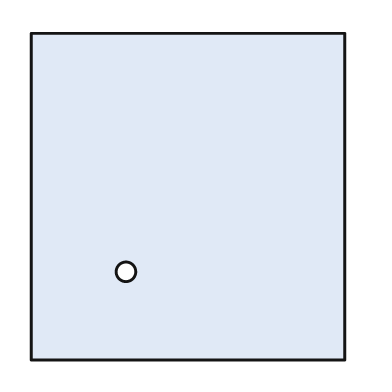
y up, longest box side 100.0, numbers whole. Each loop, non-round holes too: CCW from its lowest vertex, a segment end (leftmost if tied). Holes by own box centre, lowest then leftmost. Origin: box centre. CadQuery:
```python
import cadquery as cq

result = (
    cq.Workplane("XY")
    .moveTo(-48.0, -50.0)
    .lineTo(48.0, -50.0)
    .lineTo(48.0, 50.0)
    .lineTo(-48.0, 50.0)
    .close()
    .moveTo(-19.0, -23.0)
    .circle(3.0)
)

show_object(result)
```